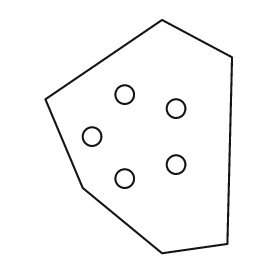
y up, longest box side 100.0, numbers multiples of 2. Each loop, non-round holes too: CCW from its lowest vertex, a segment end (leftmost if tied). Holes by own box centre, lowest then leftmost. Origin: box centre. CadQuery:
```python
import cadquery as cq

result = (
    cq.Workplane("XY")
    .moveTo(10.0, -50.0)
    .lineTo(38.0, -46.0)
    .lineTo(40.0, 34.0)
    .lineTo(10.0, 50.0)
    .lineTo(-40.0, 16.0)
    .lineTo(-24.0, -22.0)
    .close()
    .moveTo(-6.0, -18.0)
    .circle(4.0)
    .moveTo(16.0, -12.0)
    .circle(4.0)
    .moveTo(-20.0, 0.0)
    .circle(4.0)
    .moveTo(16.0, 12.0)
    .circle(4.0)
    .moveTo(-6.0, 18.0)
    .circle(4.0)
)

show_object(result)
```